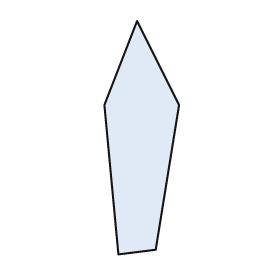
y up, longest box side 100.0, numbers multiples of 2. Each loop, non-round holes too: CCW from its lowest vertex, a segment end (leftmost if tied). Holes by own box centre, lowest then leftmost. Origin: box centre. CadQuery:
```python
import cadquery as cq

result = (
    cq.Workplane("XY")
    .moveTo(-10.0, -50.0)
    .lineTo(6.0, -48.0)
    .lineTo(16.0, 14.0)
    .lineTo(-2.0, 50.0)
    .lineTo(-16.0, 14.0)
    .close()
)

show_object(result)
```